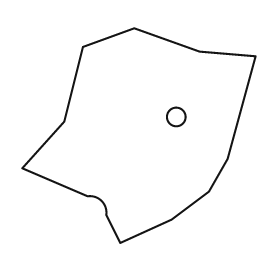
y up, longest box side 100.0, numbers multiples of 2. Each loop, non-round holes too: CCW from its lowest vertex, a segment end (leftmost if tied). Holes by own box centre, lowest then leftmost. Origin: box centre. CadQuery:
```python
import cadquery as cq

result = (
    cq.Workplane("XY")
    .moveTo(-8.0, -46.0)
    .lineTo(14.0, -36.0)
    .lineTo(30.0, -24.0)
    .lineTo(38.0, -10.0)
    .lineTo(50.0, 34.0)
    .lineTo(26.0, 36.0)
    .lineTo(-2.0, 46.0)
    .lineTo(-24.0, 38.0)
    .lineTo(-32.0, 6.0)
    .lineTo(-50.0, -14.0)
    .lineTo(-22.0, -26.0)
    .threePointArc((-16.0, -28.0), (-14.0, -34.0))
    .close()
    .moveTo(16.0, 8.0)
    .circle(4.0)
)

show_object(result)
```